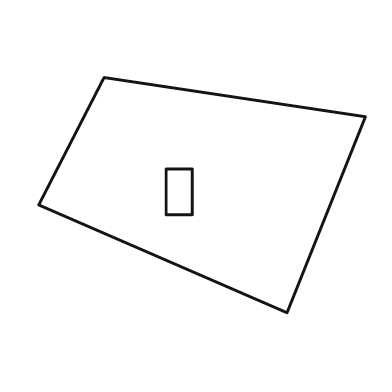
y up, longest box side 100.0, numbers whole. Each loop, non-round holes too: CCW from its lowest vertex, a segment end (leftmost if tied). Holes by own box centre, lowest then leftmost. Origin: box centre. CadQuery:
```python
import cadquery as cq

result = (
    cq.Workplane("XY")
    .moveTo(26.0, -36.0)
    .lineTo(50.0, 24.0)
    .lineTo(-30.0, 36.0)
    .lineTo(-50.0, -3.0)
    .close()
    .moveTo(-11.0, -6.0)
    .lineTo(-3.0, -6.0)
    .lineTo(-3.0, 8.0)
    .lineTo(-11.0, 8.0)
    .close()
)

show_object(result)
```